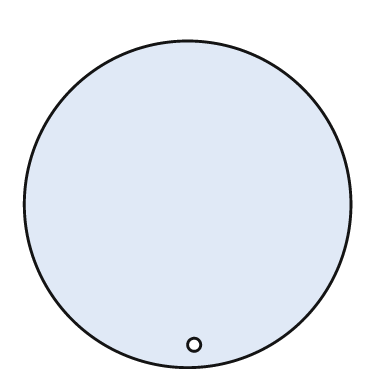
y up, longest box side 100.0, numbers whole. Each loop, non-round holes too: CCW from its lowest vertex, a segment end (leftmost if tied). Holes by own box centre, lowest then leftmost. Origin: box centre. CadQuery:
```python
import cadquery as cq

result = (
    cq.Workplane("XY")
    .moveTo(0.0, 0.0)
    .circle(50.0)
    .moveTo(2.0, -43.0)
    .circle(2.0)
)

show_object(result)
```